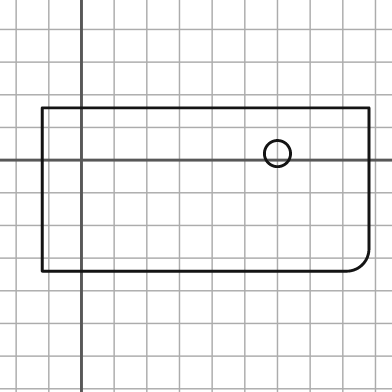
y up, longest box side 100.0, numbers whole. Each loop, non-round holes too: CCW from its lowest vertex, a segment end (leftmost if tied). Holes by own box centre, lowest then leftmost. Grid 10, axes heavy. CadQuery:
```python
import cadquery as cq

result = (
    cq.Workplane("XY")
    .moveTo(-12.0, -34.0)
    .lineTo(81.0, -34.0)
    .threePointArc((86.0, -32.0), (88.0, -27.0))
    .lineTo(88.0, 16.0)
    .lineTo(-12.0, 16.0)
    .close()
    .moveTo(60.0, 2.0)
    .circle(4.0)
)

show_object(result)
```